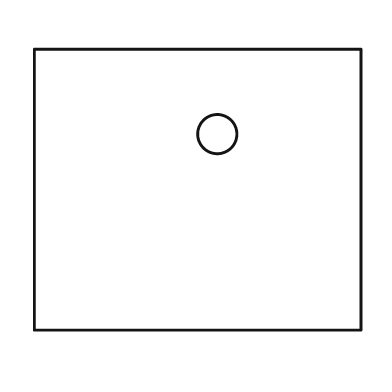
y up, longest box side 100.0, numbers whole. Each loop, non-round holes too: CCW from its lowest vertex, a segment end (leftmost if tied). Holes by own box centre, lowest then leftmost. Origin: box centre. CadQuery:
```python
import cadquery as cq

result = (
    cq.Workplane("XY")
    .moveTo(-50.0, -43.0)
    .lineTo(50.0, -43.0)
    .lineTo(50.0, 43.0)
    .lineTo(-50.0, 43.0)
    .close()
    .moveTo(6.0, 17.0)
    .circle(6.0)
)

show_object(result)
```